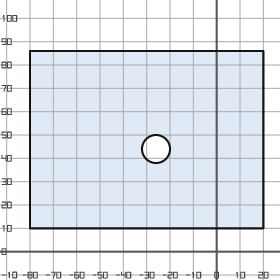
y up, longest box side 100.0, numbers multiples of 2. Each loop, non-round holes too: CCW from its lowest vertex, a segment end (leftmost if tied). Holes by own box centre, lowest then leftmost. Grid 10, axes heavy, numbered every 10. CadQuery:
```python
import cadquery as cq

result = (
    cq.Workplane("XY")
    .moveTo(-80.0, 10.0)
    .lineTo(20.0, 10.0)
    .lineTo(20.0, 86.0)
    .lineTo(-80.0, 86.0)
    .close()
    .moveTo(-26.0, 44.0)
    .circle(6.0)
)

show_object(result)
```